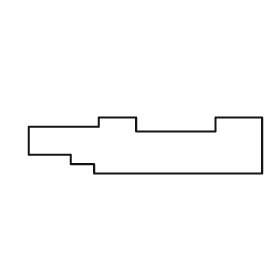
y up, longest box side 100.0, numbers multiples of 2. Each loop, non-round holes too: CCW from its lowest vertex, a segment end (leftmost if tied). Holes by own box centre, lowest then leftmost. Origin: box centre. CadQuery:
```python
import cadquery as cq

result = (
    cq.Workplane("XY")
    .moveTo(-22.0, -12.0)
    .lineTo(50.0, -12.0)
    .lineTo(50.0, 12.0)
    .lineTo(30.0, 12.0)
    .lineTo(30.0, 6.0)
    .lineTo(-4.0, 6.0)
    .lineTo(-4.0, 12.0)
    .lineTo(-20.0, 12.0)
    .lineTo(-20.0, 8.0)
    .lineTo(-50.0, 8.0)
    .lineTo(-50.0, -4.0)
    .lineTo(-32.0, -4.0)
    .lineTo(-32.0, -8.0)
    .lineTo(-22.0, -8.0)
    .close()
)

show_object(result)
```